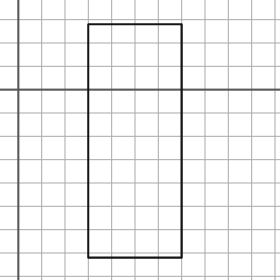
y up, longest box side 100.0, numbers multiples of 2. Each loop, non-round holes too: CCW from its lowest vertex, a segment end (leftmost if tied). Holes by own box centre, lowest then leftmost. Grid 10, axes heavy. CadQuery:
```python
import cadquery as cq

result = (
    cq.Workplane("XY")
    .moveTo(30.0, -72.0)
    .lineTo(70.0, -72.0)
    .lineTo(70.0, 28.0)
    .lineTo(30.0, 28.0)
    .close()
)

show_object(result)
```